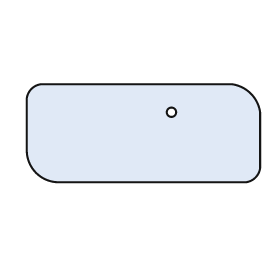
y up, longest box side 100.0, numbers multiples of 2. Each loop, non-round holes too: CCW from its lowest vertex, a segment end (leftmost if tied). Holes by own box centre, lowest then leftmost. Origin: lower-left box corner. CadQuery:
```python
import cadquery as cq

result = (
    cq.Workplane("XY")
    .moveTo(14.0, 0.0)
    .lineTo(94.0, 0.0)
    .threePointArc((98.0, 2.0), (100.0, 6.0))
    .lineTo(100.0, 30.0)
    .threePointArc((96.0, 38.0), (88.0, 42.0))
    .lineTo(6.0, 42.0)
    .threePointArc((2.0, 40.0), (0.0, 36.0))
    .lineTo(0.0, 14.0)
    .threePointArc((4.0, 4.0), (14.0, 0.0))
    .close()
    .moveTo(62.0, 30.0)
    .circle(2.0)
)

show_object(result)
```